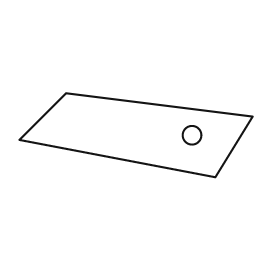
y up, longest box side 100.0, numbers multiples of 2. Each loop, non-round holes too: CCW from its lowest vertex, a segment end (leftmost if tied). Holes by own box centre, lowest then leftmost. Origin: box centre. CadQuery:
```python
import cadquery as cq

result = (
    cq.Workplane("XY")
    .moveTo(34.0, -18.0)
    .lineTo(50.0, 8.0)
    .lineTo(-30.0, 18.0)
    .lineTo(-50.0, -2.0)
    .close()
    .moveTo(24.0, 0.0)
    .circle(4.0)
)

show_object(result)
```